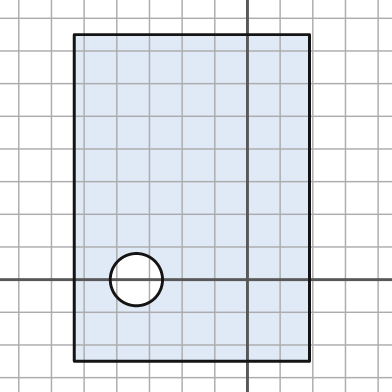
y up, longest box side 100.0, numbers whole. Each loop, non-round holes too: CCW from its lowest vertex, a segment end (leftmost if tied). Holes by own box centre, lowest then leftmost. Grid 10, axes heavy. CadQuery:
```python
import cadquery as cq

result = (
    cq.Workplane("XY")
    .moveTo(-53.0, -25.0)
    .lineTo(19.0, -25.0)
    .lineTo(19.0, 75.0)
    .lineTo(-53.0, 75.0)
    .close()
    .moveTo(-34.0, 0.0)
    .circle(8.0)
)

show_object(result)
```